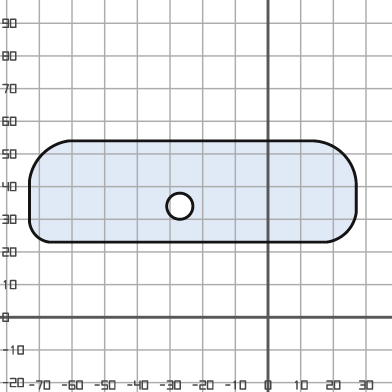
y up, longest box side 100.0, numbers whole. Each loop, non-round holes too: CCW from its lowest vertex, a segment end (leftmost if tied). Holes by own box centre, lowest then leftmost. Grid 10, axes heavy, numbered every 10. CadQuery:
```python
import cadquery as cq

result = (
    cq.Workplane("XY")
    .moveTo(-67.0, 23.0)
    .lineTo(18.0, 23.0)
    .threePointArc((24.0, 26.0), (27.0, 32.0))
    .lineTo(27.0, 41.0)
    .threePointArc((23.0, 50.0), (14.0, 54.0))
    .lineTo(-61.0, 54.0)
    .threePointArc((-69.0, 50.0), (-73.0, 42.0))
    .lineTo(-73.0, 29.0)
    .threePointArc((-71.0, 25.0), (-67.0, 23.0))
    .close()
    .moveTo(-27.0, 34.0)
    .circle(4.0)
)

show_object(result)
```